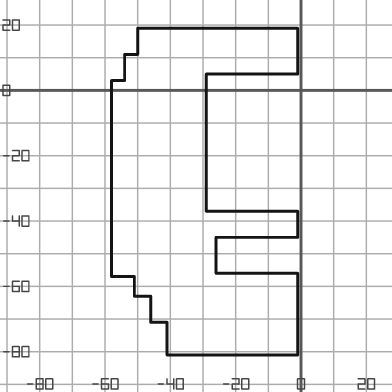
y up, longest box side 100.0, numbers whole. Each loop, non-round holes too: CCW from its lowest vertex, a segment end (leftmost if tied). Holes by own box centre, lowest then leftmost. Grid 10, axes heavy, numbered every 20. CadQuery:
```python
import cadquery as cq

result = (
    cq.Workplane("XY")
    .moveTo(-41.0, -81.0)
    .lineTo(-1.0, -81.0)
    .lineTo(-1.0, -56.0)
    .lineTo(-26.0, -56.0)
    .lineTo(-26.0, -45.0)
    .lineTo(-1.0, -45.0)
    .lineTo(-1.0, -37.0)
    .lineTo(-29.0, -37.0)
    .lineTo(-29.0, 5.0)
    .lineTo(-1.0, 5.0)
    .lineTo(-1.0, 19.0)
    .lineTo(-50.0, 19.0)
    .lineTo(-50.0, 11.0)
    .lineTo(-54.0, 11.0)
    .lineTo(-54.0, 3.0)
    .lineTo(-58.0, 3.0)
    .lineTo(-58.0, -57.0)
    .lineTo(-51.0, -57.0)
    .lineTo(-51.0, -63.0)
    .lineTo(-46.0, -63.0)
    .lineTo(-46.0, -71.0)
    .lineTo(-41.0, -71.0)
    .close()
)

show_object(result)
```